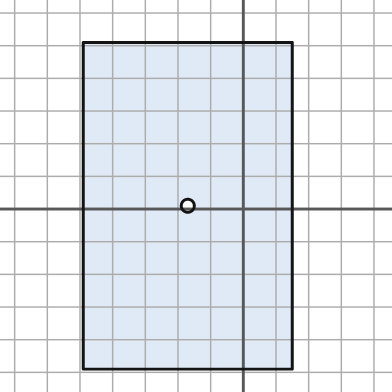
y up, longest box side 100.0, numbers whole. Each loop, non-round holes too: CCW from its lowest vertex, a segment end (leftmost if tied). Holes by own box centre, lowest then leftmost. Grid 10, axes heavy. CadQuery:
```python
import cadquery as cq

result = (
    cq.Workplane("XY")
    .moveTo(-49.0, -49.0)
    .lineTo(15.0, -49.0)
    .lineTo(15.0, 51.0)
    .lineTo(-49.0, 51.0)
    .close()
    .moveTo(-17.0, 1.0)
    .circle(2.0)
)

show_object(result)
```